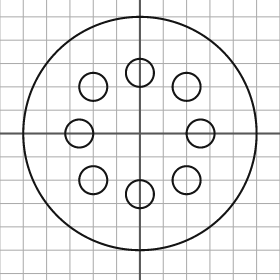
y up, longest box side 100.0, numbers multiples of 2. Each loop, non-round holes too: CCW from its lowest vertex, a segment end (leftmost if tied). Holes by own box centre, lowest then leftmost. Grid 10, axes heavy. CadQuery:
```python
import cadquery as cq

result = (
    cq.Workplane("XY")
    .moveTo(0.0, 0.0)
    .circle(50.0)
    .moveTo(0.0, -26.0)
    .circle(6.0)
    .moveTo(-20.0, -20.0)
    .circle(6.0)
    .moveTo(20.0, -20.0)
    .circle(6.0)
    .moveTo(-26.0, 0.0)
    .circle(6.0)
    .moveTo(26.0, 0.0)
    .circle(6.0)
    .moveTo(-20.0, 20.0)
    .circle(6.0)
    .moveTo(20.0, 20.0)
    .circle(6.0)
    .moveTo(0.0, 26.0)
    .circle(6.0)
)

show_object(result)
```